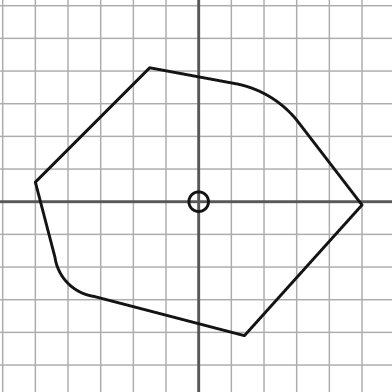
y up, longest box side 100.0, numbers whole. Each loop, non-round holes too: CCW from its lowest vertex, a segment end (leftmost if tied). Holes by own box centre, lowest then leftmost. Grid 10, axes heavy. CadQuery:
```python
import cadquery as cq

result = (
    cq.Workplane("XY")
    .moveTo(14.0, -41.0)
    .lineTo(50.0, -1.0)
    .lineTo(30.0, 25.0)
    .threePointArc((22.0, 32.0), (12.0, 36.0))
    .lineTo(-15.0, 41.0)
    .lineTo(-50.0, 6.0)
    .lineTo(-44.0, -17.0)
    .threePointArc((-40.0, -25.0), (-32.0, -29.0))
    .close()
    .moveTo(0.0, 0.0)
    .circle(3.0)
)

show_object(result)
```